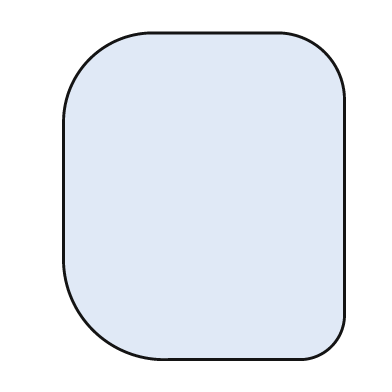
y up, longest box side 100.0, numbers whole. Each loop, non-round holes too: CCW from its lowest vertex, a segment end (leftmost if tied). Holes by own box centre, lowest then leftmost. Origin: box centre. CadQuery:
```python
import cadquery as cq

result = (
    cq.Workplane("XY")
    .moveTo(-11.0, -50.0)
    .lineTo(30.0, -50.0)
    .threePointArc((39.0, -46.0), (43.0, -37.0))
    .lineTo(43.0, 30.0)
    .threePointArc((37.0, 44.0), (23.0, 50.0))
    .lineTo(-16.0, 50.0)
    .threePointArc((-35.0, 42.0), (-43.0, 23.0))
    .lineTo(-43.0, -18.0)
    .threePointArc((-34.0, -41.0), (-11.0, -50.0))
    .close()
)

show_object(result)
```